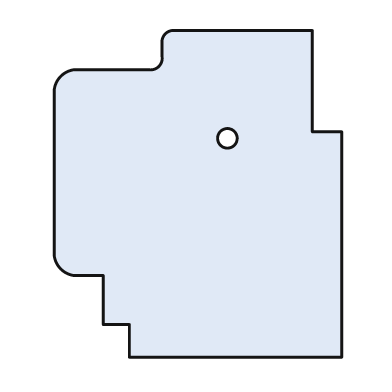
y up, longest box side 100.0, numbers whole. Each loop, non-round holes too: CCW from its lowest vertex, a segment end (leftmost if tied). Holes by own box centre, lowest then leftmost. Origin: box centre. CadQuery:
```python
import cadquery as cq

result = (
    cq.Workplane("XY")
    .moveTo(-21.0, -50.0)
    .lineTo(44.0, -50.0)
    .lineTo(44.0, 19.0)
    .lineTo(35.0, 19.0)
    .lineTo(35.0, 50.0)
    .lineTo(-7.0, 50.0)
    .threePointArc((-10.0, 49.0), (-11.0, 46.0))
    .lineTo(-11.0, 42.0)
    .threePointArc((-12.0, 39.0), (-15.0, 38.0))
    .lineTo(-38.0, 38.0)
    .threePointArc((-42.0, 36.0), (-44.0, 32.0))
    .lineTo(-44.0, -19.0)
    .threePointArc((-42.0, -23.0), (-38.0, -25.0))
    .lineTo(-29.0, -25.0)
    .lineTo(-29.0, -40.0)
    .lineTo(-21.0, -40.0)
    .close()
    .moveTo(9.0, 17.0)
    .circle(3.0)
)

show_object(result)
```